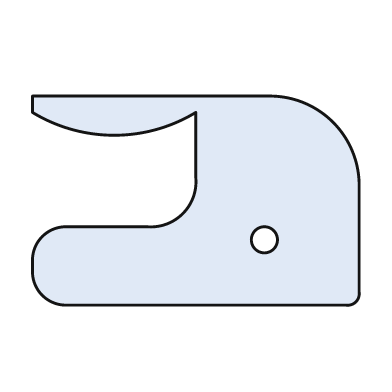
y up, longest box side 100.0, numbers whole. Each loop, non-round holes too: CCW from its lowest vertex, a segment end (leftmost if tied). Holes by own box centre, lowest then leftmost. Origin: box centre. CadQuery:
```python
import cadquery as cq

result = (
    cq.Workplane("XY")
    .moveTo(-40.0, -32.0)
    .lineTo(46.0, -32.0)
    .threePointArc((49.0, -31.0), (50.0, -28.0))
    .lineTo(50.0, 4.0)
    .threePointArc((42.0, 24.0), (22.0, 32.0))
    .lineTo(-50.0, 32.0)
    .lineTo(-50.0, 27.0)
    .threePointArc((-25.0, 20.0), (0.0, 27.0))
    .lineTo(0.0, 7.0)
    .threePointArc((-4.0, -4.0), (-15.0, -8.0))
    .lineTo(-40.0, -8.0)
    .threePointArc((-47.0, -11.0), (-50.0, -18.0))
    .lineTo(-50.0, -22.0)
    .threePointArc((-47.0, -29.0), (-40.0, -32.0))
    .close()
    .moveTo(21.0, -12.0)
    .circle(4.0)
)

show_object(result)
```